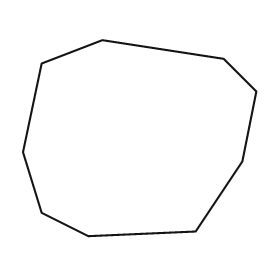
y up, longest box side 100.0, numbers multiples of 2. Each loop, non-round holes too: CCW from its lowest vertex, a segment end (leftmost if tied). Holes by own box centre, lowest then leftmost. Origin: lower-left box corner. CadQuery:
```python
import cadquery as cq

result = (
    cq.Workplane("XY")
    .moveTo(28.0, 0.0)
    .lineTo(74.0, 2.0)
    .lineTo(94.0, 32.0)
    .lineTo(100.0, 62.0)
    .lineTo(86.0, 76.0)
    .lineTo(34.0, 84.0)
    .lineTo(8.0, 74.0)
    .lineTo(0.0, 36.0)
    .lineTo(8.0, 10.0)
    .close()
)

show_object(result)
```